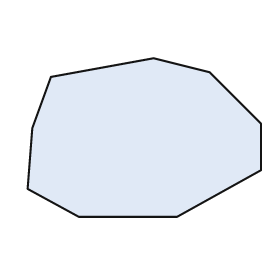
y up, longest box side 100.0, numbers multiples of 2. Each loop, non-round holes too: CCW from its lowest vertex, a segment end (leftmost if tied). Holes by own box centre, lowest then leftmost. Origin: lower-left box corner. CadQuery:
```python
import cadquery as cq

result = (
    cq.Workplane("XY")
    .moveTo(22.0, 0.0)
    .lineTo(64.0, 0.0)
    .lineTo(100.0, 20.0)
    .lineTo(100.0, 40.0)
    .lineTo(78.0, 62.0)
    .lineTo(54.0, 68.0)
    .lineTo(10.0, 60.0)
    .lineTo(2.0, 38.0)
    .lineTo(0.0, 12.0)
    .close()
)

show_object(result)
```